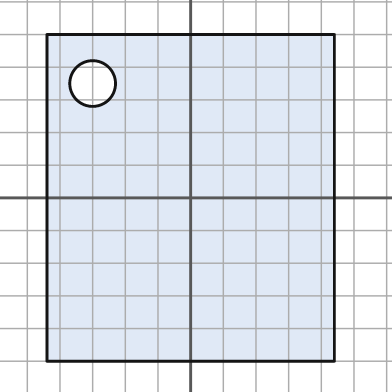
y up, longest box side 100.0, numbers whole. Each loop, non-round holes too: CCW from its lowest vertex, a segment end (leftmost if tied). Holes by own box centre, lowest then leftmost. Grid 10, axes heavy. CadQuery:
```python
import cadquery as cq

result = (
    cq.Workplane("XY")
    .moveTo(-44.0, -50.0)
    .lineTo(44.0, -50.0)
    .lineTo(44.0, 50.0)
    .lineTo(-44.0, 50.0)
    .close()
    .moveTo(-30.0, 35.0)
    .circle(7.0)
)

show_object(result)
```